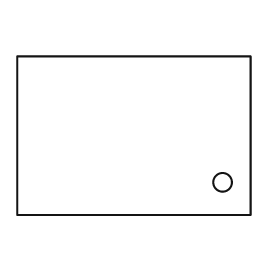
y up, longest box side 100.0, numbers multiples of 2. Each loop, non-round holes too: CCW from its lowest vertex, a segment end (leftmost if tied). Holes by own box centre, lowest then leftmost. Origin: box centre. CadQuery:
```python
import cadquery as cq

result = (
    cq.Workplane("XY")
    .moveTo(-50.0, -34.0)
    .lineTo(50.0, -34.0)
    .lineTo(50.0, 34.0)
    .lineTo(-50.0, 34.0)
    .close()
    .moveTo(38.0, -20.0)
    .circle(4.0)
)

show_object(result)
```